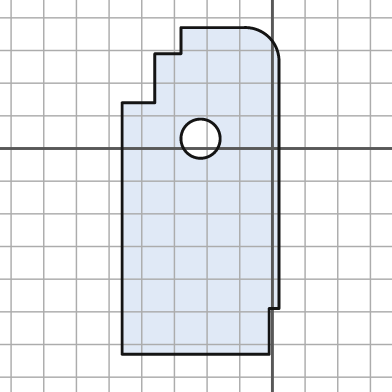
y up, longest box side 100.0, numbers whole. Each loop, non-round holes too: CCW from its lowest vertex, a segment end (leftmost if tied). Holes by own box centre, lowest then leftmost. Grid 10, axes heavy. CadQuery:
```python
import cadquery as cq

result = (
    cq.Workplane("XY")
    .moveTo(-46.0, -63.0)
    .lineTo(-1.0, -63.0)
    .lineTo(-1.0, -49.0)
    .lineTo(2.0, -49.0)
    .lineTo(2.0, 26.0)
    .threePointArc((-1.0, 34.0), (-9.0, 37.0))
    .lineTo(-28.0, 37.0)
    .lineTo(-28.0, 29.0)
    .lineTo(-36.0, 29.0)
    .lineTo(-36.0, 14.0)
    .lineTo(-46.0, 14.0)
    .close()
    .moveTo(-22.0, 3.0)
    .circle(6.0)
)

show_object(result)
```